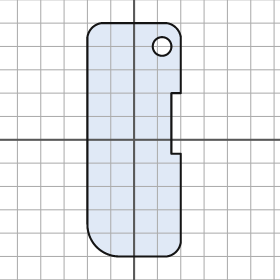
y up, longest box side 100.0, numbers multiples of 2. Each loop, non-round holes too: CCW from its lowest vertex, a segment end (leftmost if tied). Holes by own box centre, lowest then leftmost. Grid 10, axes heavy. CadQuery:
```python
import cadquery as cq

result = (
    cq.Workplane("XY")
    .moveTo(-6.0, -50.0)
    .lineTo(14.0, -50.0)
    .threePointArc((18.0, -48.0), (20.0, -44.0))
    .lineTo(20.0, -6.0)
    .lineTo(16.0, -6.0)
    .lineTo(16.0, 20.0)
    .lineTo(20.0, 20.0)
    .lineTo(20.0, 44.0)
    .threePointArc((18.0, 48.0), (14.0, 50.0))
    .lineTo(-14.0, 50.0)
    .threePointArc((-18.0, 48.0), (-20.0, 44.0))
    .lineTo(-20.0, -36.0)
    .threePointArc((-16.0, -46.0), (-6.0, -50.0))
    .close()
    .moveTo(12.0, 40.0)
    .circle(4.0)
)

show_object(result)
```